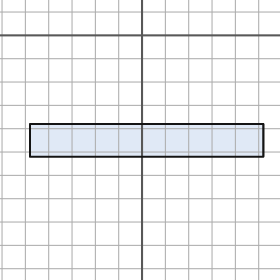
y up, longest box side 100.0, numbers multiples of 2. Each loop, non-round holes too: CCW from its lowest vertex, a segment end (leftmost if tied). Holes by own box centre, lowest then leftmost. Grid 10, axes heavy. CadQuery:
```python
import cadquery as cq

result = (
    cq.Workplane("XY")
    .moveTo(-48.0, -52.0)
    .lineTo(52.0, -52.0)
    .lineTo(52.0, -38.0)
    .lineTo(-48.0, -38.0)
    .close()
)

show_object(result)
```